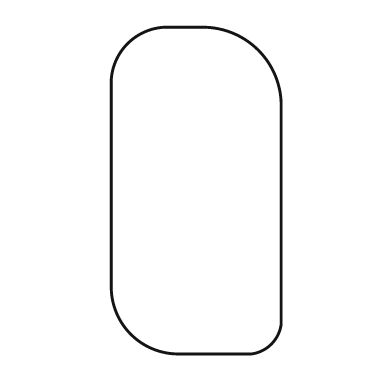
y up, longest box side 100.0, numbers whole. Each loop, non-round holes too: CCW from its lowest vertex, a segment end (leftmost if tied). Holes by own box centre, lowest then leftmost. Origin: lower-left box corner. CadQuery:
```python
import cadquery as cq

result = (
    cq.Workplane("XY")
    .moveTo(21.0, 0.0)
    .lineTo(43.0, 0.0)
    .threePointArc((49.0, 3.0), (52.0, 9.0))
    .lineTo(52.0, 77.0)
    .threePointArc((45.0, 93.0), (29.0, 100.0))
    .lineTo(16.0, 100.0)
    .threePointArc((5.0, 95.0), (0.0, 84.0))
    .lineTo(0.0, 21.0)
    .threePointArc((6.0, 6.0), (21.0, 0.0))
    .close()
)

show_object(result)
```